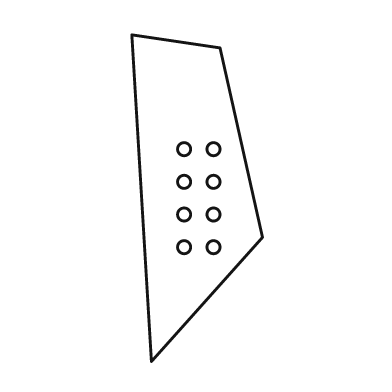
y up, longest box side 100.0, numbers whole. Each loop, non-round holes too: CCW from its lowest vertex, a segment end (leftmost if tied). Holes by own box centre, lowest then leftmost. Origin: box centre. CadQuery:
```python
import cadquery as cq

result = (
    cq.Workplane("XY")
    .moveTo(-14.0, -50.0)
    .lineTo(20.0, -12.0)
    .lineTo(7.0, 46.0)
    .lineTo(-20.0, 50.0)
    .close()
    .moveTo(-4.0, -15.0)
    .circle(2.0)
    .moveTo(5.0, -15.0)
    .circle(2.0)
    .moveTo(-4.0, -5.0)
    .circle(2.0)
    .moveTo(5.0, -5.0)
    .circle(2.0)
    .moveTo(-4.0, 5.0)
    .circle(2.0)
    .moveTo(5.0, 5.0)
    .circle(2.0)
    .moveTo(-4.0, 15.0)
    .circle(2.0)
    .moveTo(5.0, 15.0)
    .circle(2.0)
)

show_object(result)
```